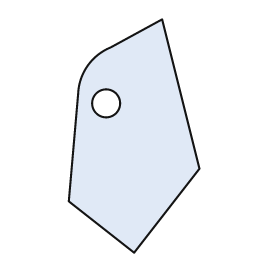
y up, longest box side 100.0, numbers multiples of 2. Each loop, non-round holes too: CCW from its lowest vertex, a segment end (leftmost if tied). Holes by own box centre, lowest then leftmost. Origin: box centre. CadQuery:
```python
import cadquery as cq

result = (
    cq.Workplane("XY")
    .moveTo(0.0, -50.0)
    .lineTo(28.0, -14.0)
    .lineTo(12.0, 50.0)
    .lineTo(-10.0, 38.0)
    .threePointArc((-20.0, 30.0), (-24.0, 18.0))
    .lineTo(-28.0, -28.0)
    .close()
    .moveTo(-12.0, 14.0)
    .circle(6.0)
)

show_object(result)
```